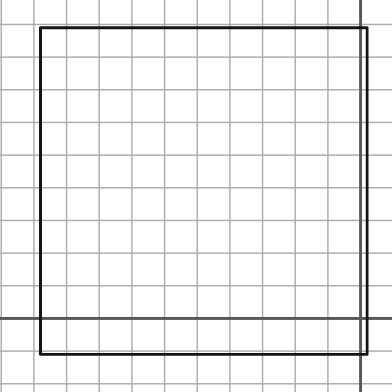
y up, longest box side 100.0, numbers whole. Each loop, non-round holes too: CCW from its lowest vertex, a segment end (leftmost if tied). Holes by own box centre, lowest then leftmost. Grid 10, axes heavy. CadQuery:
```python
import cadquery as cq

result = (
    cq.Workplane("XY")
    .moveTo(-98.0, -11.0)
    .lineTo(2.0, -11.0)
    .lineTo(2.0, 89.0)
    .lineTo(-98.0, 89.0)
    .close()
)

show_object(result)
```